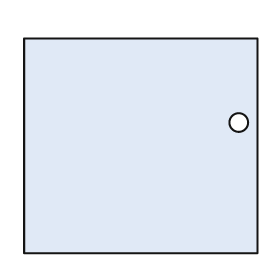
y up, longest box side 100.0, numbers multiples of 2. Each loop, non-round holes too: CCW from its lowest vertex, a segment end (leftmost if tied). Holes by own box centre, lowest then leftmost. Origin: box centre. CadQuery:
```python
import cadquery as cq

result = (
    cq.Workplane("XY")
    .moveTo(-50.0, -46.0)
    .lineTo(50.0, -46.0)
    .lineTo(50.0, 46.0)
    .lineTo(-50.0, 46.0)
    .close()
    .moveTo(42.0, 10.0)
    .circle(4.0)
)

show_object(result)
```